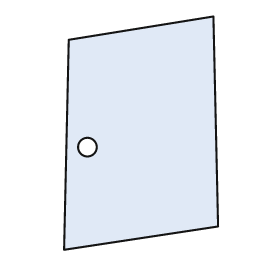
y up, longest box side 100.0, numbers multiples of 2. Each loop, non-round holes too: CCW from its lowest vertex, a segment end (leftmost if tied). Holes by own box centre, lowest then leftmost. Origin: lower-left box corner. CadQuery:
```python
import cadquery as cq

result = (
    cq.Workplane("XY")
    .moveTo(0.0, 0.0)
    .lineTo(66.0, 10.0)
    .lineTo(64.0, 100.0)
    .lineTo(2.0, 90.0)
    .close()
    .moveTo(10.0, 44.0)
    .circle(4.0)
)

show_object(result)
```